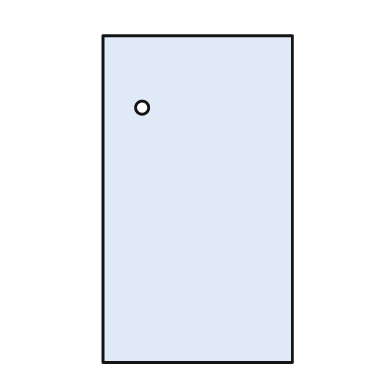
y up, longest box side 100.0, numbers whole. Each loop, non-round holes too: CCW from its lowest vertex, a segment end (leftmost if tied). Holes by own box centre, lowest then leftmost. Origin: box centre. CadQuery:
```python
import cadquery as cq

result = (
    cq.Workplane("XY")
    .moveTo(-29.0, -50.0)
    .lineTo(29.0, -50.0)
    .lineTo(29.0, 50.0)
    .lineTo(-29.0, 50.0)
    .close()
    .moveTo(-17.0, 28.0)
    .circle(2.0)
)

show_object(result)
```